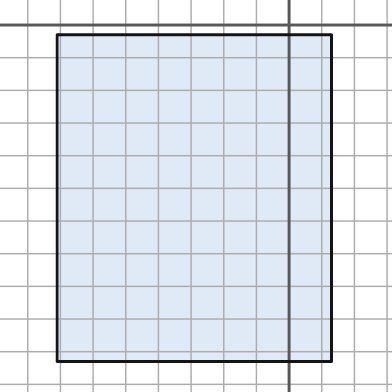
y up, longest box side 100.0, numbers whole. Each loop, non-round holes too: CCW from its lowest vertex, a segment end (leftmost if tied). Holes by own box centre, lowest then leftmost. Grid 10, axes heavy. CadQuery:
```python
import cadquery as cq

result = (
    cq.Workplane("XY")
    .moveTo(-71.0, -103.0)
    .lineTo(13.0, -103.0)
    .lineTo(13.0, -3.0)
    .lineTo(-71.0, -3.0)
    .close()
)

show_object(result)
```